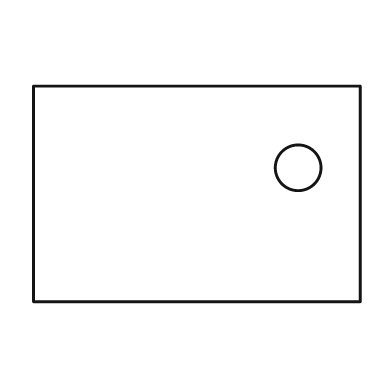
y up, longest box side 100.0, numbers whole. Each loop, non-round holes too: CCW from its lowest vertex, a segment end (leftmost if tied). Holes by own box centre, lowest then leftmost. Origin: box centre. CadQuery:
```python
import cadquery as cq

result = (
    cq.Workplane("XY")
    .moveTo(-50.0, -33.0)
    .lineTo(50.0, -33.0)
    .lineTo(50.0, 33.0)
    .lineTo(-50.0, 33.0)
    .close()
    .moveTo(31.0, 8.0)
    .circle(7.0)
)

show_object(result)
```